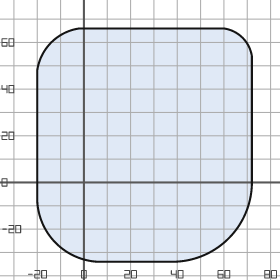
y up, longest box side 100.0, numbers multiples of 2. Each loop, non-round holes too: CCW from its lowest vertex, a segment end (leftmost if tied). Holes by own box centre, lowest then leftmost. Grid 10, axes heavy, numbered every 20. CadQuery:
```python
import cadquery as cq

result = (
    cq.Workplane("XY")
    .moveTo(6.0, -34.0)
    .lineTo(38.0, -34.0)
    .threePointArc((62.0, -24.0), (72.0, 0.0))
    .lineTo(72.0, 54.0)
    .threePointArc((68.0, 62.0), (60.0, 66.0))
    .lineTo(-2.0, 66.0)
    .threePointArc((-14.0, 60.0), (-20.0, 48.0))
    .lineTo(-20.0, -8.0)
    .threePointArc((-12.0, -26.0), (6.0, -34.0))
    .close()
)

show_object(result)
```